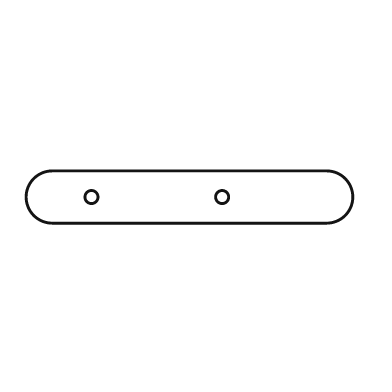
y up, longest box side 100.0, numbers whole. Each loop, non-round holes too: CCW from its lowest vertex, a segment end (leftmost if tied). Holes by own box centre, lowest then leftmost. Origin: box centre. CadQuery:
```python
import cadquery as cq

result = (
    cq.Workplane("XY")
    .moveTo(-42.0, -8.0)
    .lineTo(42.0, -8.0)
    .threePointArc((50.0, 0.0), (42.0, 8.0))
    .lineTo(-42.0, 8.0)
    .threePointArc((-50.0, 0.0), (-42.0, -8.0))
    .close()
    .moveTo(-30.0, 0.0)
    .circle(2.0)
    .moveTo(10.0, 0.0)
    .circle(2.0)
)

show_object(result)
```